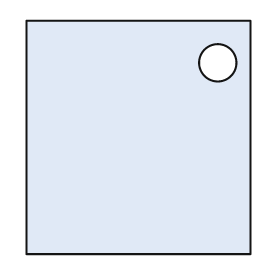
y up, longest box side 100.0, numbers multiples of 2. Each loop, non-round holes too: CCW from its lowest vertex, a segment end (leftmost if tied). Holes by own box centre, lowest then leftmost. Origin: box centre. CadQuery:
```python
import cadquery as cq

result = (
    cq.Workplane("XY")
    .moveTo(-48.0, -50.0)
    .lineTo(48.0, -50.0)
    .lineTo(48.0, 50.0)
    .lineTo(-48.0, 50.0)
    .close()
    .moveTo(34.0, 32.0)
    .circle(8.0)
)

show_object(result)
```